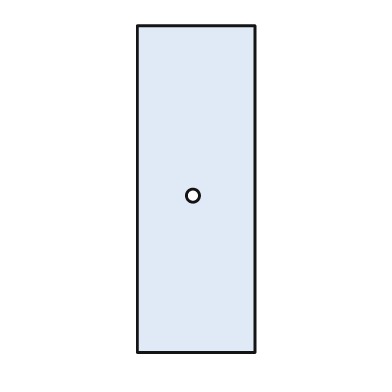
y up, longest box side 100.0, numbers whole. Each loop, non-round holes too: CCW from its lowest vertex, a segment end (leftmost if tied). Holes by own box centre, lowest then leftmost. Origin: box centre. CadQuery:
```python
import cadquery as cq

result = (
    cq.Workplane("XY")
    .moveTo(-18.0, -50.0)
    .lineTo(18.0, -50.0)
    .lineTo(18.0, 50.0)
    .lineTo(-18.0, 50.0)
    .close()
    .moveTo(-1.0, -2.0)
    .circle(2.0)
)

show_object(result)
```